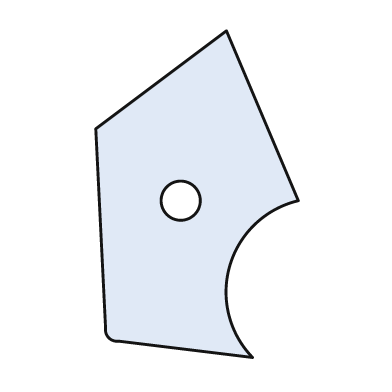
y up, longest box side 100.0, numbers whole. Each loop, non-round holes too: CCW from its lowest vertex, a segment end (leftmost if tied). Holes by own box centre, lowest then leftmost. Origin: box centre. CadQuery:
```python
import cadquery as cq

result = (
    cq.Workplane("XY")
    .moveTo(17.0, -50.0)
    .threePointArc((10.0, -22.0), (31.0, -2.0))
    .lineTo(9.0, 50.0)
    .lineTo(-31.0, 20.0)
    .lineTo(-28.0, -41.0)
    .threePointArc((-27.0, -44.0), (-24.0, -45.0))
    .close()
    .moveTo(-5.0, -2.0)
    .circle(6.0)
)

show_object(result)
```